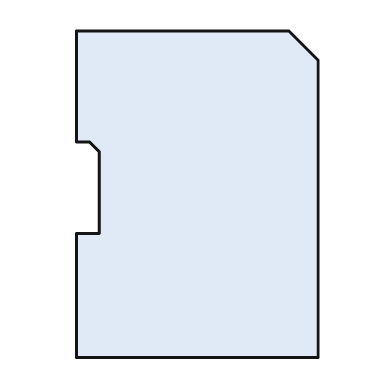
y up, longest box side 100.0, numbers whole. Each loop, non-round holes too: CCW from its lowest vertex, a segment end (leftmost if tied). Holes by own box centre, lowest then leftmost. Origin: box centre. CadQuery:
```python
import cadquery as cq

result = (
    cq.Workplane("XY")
    .moveTo(-37.0, -50.0)
    .lineTo(37.0, -50.0)
    .lineTo(37.0, 41.0)
    .lineTo(28.0, 50.0)
    .lineTo(-37.0, 50.0)
    .lineTo(-37.0, 16.0)
    .lineTo(-33.0, 16.0)
    .lineTo(-30.0, 13.0)
    .lineTo(-30.0, -12.0)
    .lineTo(-37.0, -12.0)
    .close()
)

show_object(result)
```